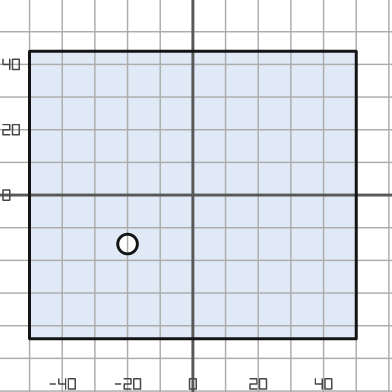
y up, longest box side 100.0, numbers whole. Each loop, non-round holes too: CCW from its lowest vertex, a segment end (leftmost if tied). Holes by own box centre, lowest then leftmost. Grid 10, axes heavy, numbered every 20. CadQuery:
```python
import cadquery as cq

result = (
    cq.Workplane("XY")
    .moveTo(-50.0, -44.0)
    .lineTo(50.0, -44.0)
    .lineTo(50.0, 44.0)
    .lineTo(-50.0, 44.0)
    .close()
    .moveTo(-20.0, -15.0)
    .circle(3.0)
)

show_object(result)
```